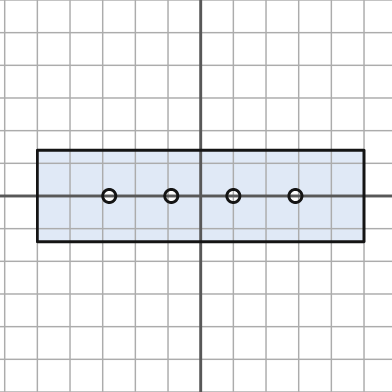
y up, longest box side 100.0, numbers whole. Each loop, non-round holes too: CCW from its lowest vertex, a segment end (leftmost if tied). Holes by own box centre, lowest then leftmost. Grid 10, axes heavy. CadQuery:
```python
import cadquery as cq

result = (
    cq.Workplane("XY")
    .moveTo(-50.0, -14.0)
    .lineTo(50.0, -14.0)
    .lineTo(50.0, 14.0)
    .lineTo(-50.0, 14.0)
    .close()
    .moveTo(-28.0, 0.0)
    .circle(2.0)
    .moveTo(-9.0, 0.0)
    .circle(2.0)
    .moveTo(10.0, 0.0)
    .circle(2.0)
    .moveTo(29.0, 0.0)
    .circle(2.0)
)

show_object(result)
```